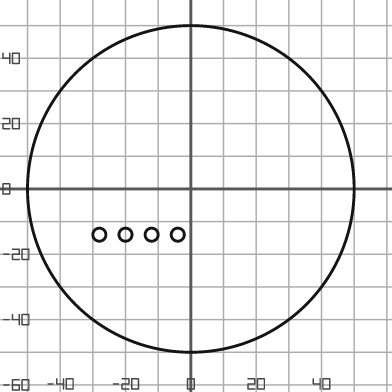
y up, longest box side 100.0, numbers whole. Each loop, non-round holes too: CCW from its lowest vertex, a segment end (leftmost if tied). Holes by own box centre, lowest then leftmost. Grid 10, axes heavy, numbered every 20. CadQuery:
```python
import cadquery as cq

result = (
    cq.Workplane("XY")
    .moveTo(0.0, 0.0)
    .circle(50.0)
    .moveTo(-28.0, -14.0)
    .circle(2.0)
    .moveTo(-20.0, -14.0)
    .circle(2.0)
    .moveTo(-12.0, -14.0)
    .circle(2.0)
    .moveTo(-4.0, -14.0)
    .circle(2.0)
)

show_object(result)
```